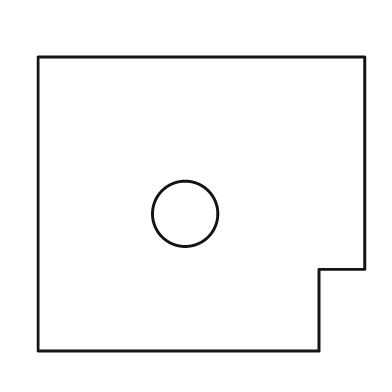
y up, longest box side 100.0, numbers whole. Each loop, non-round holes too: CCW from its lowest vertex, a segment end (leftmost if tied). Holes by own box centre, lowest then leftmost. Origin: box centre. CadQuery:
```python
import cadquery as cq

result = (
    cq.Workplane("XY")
    .moveTo(-50.0, -45.0)
    .lineTo(36.0, -45.0)
    .lineTo(36.0, -20.0)
    .lineTo(50.0, -20.0)
    .lineTo(50.0, 45.0)
    .lineTo(-50.0, 45.0)
    .close()
    .moveTo(-5.0, -3.0)
    .circle(10.0)
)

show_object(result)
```